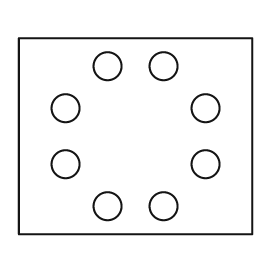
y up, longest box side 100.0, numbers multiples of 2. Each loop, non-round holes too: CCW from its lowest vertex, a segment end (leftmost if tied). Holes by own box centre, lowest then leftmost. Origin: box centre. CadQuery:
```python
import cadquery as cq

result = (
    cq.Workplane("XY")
    .moveTo(-50.0, -42.0)
    .lineTo(50.0, -42.0)
    .lineTo(50.0, 42.0)
    .lineTo(-50.0, 42.0)
    .close()
    .moveTo(-12.0, -30.0)
    .circle(6.0)
    .moveTo(12.0, -30.0)
    .circle(6.0)
    .moveTo(-30.0, -12.0)
    .circle(6.0)
    .moveTo(30.0, -12.0)
    .circle(6.0)
    .moveTo(-30.0, 12.0)
    .circle(6.0)
    .moveTo(30.0, 12.0)
    .circle(6.0)
    .moveTo(-12.0, 30.0)
    .circle(6.0)
    .moveTo(12.0, 30.0)
    .circle(6.0)
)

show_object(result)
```